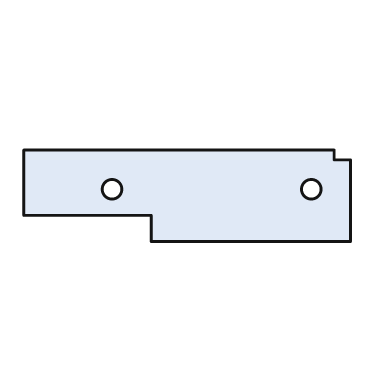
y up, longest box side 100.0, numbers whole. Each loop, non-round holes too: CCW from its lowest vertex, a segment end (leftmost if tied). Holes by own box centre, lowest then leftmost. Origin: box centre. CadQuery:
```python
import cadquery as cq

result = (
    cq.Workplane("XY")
    .moveTo(-11.0, -14.0)
    .lineTo(50.0, -14.0)
    .lineTo(50.0, 11.0)
    .lineTo(45.0, 11.0)
    .lineTo(45.0, 14.0)
    .lineTo(-50.0, 14.0)
    .lineTo(-50.0, -6.0)
    .lineTo(-11.0, -6.0)
    .close()
    .moveTo(-23.0, 2.0)
    .circle(3.0)
    .moveTo(38.0, 2.0)
    .circle(3.0)
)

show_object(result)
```